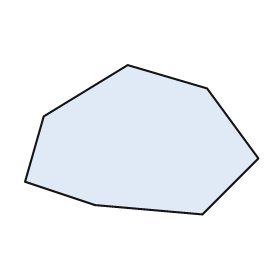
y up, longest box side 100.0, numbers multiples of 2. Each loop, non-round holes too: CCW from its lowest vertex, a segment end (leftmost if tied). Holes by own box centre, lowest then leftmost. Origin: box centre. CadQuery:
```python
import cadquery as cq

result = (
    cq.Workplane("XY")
    .moveTo(26.0, -32.0)
    .lineTo(50.0, -8.0)
    .lineTo(28.0, 22.0)
    .lineTo(-6.0, 32.0)
    .lineTo(-42.0, 10.0)
    .lineTo(-50.0, -18.0)
    .lineTo(-20.0, -28.0)
    .close()
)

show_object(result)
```